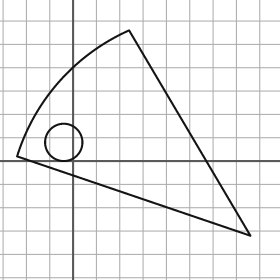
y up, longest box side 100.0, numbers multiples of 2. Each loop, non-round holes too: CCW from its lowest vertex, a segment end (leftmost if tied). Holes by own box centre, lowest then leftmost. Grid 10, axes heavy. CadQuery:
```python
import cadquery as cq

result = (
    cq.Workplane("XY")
    .moveTo(76.0, -32.0)
    .lineTo(24.0, 56.0)
    .threePointArc((-6.0, 34.0), (-24.0, 2.0))
    .close()
    .moveTo(-4.0, 8.0)
    .circle(8.0)
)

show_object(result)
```